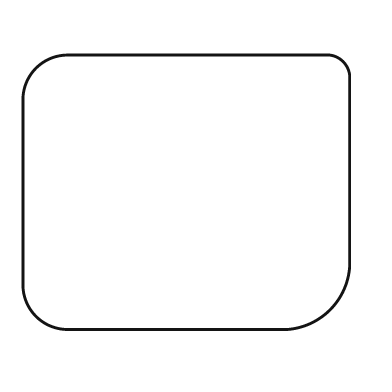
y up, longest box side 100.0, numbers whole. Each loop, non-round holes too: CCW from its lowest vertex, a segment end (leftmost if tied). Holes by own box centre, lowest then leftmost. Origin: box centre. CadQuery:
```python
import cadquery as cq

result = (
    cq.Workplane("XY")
    .moveTo(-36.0, -42.0)
    .lineTo(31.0, -42.0)
    .threePointArc((44.0, -36.0), (50.0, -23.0))
    .lineTo(50.0, 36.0)
    .threePointArc((48.0, 40.0), (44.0, 42.0))
    .lineTo(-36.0, 42.0)
    .threePointArc((-46.0, 38.0), (-50.0, 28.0))
    .lineTo(-50.0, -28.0)
    .threePointArc((-46.0, -38.0), (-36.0, -42.0))
    .close()
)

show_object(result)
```